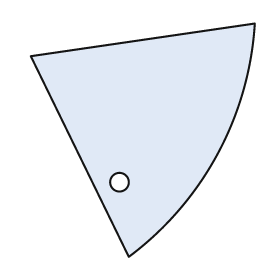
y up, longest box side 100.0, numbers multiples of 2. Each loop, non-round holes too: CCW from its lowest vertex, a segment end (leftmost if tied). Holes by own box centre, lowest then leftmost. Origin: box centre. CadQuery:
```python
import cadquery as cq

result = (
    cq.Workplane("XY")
    .moveTo(-6.0, -50.0)
    .threePointArc((32.0, -6.0), (48.0, 50.0))
    .lineTo(-48.0, 36.0)
    .close()
    .moveTo(-10.0, -18.0)
    .circle(4.0)
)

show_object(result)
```